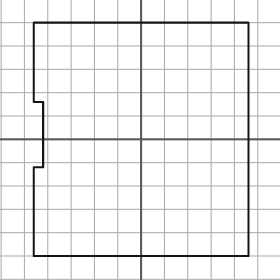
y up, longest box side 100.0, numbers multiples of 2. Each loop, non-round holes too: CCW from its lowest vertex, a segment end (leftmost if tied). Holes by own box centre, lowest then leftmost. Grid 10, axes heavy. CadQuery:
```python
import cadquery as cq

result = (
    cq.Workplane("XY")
    .moveTo(-46.0, -50.0)
    .lineTo(46.0, -50.0)
    .lineTo(46.0, 50.0)
    .lineTo(-46.0, 50.0)
    .lineTo(-46.0, 16.0)
    .lineTo(-42.0, 16.0)
    .lineTo(-42.0, -12.0)
    .lineTo(-46.0, -12.0)
    .close()
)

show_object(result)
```